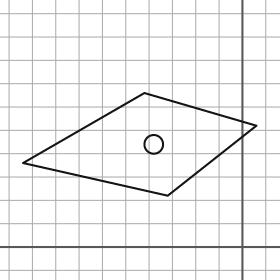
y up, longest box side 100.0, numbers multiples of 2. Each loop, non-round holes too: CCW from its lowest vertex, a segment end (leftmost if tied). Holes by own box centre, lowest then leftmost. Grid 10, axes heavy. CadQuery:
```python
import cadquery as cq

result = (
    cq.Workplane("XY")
    .moveTo(-32.0, 22.0)
    .lineTo(6.0, 52.0)
    .lineTo(-42.0, 66.0)
    .lineTo(-94.0, 36.0)
    .close()
    .moveTo(-38.0, 44.0)
    .circle(4.0)
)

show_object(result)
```